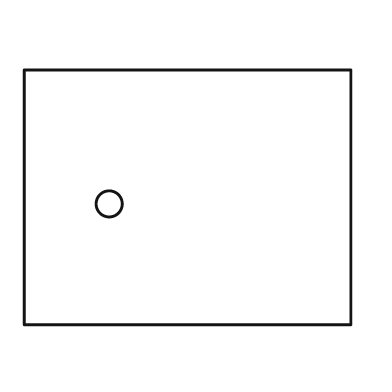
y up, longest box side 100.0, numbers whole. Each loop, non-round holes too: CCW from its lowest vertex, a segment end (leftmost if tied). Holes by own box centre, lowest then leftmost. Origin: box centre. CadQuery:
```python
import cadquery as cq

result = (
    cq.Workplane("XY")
    .moveTo(-50.0, -39.0)
    .lineTo(50.0, -39.0)
    .lineTo(50.0, 39.0)
    .lineTo(-50.0, 39.0)
    .close()
    .moveTo(-24.0, -2.0)
    .circle(4.0)
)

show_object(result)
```